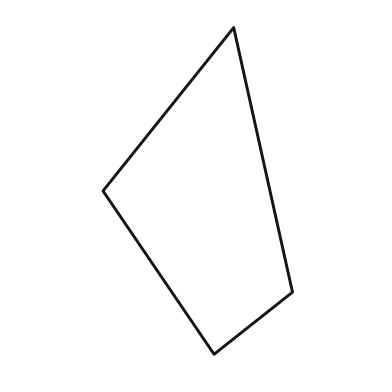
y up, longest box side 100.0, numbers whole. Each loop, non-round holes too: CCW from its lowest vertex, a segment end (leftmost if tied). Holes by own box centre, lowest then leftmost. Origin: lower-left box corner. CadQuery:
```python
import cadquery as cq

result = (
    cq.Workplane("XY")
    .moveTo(34.0, 0.0)
    .lineTo(58.0, 19.0)
    .lineTo(40.0, 100.0)
    .lineTo(0.0, 50.0)
    .close()
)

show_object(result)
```